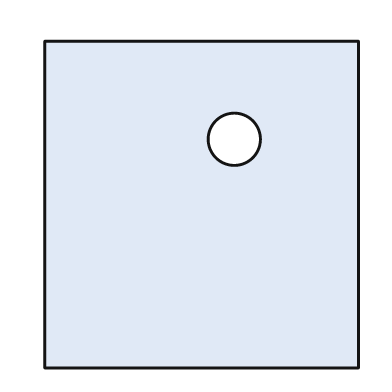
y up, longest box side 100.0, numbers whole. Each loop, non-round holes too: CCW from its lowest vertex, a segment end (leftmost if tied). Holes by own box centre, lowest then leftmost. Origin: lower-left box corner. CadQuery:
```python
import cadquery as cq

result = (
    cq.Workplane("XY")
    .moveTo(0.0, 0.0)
    .lineTo(96.0, 0.0)
    .lineTo(96.0, 100.0)
    .lineTo(0.0, 100.0)
    .close()
    .moveTo(58.0, 70.0)
    .circle(8.0)
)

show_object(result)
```